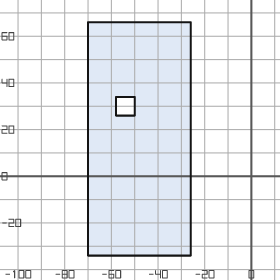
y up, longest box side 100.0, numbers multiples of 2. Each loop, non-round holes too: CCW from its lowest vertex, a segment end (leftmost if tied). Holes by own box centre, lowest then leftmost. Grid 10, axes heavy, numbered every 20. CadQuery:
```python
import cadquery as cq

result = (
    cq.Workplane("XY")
    .moveTo(-70.0, -34.0)
    .lineTo(-26.0, -34.0)
    .lineTo(-26.0, 66.0)
    .lineTo(-70.0, 66.0)
    .close()
    .moveTo(-58.0, 26.0)
    .lineTo(-50.0, 26.0)
    .lineTo(-50.0, 34.0)
    .lineTo(-58.0, 34.0)
    .close()
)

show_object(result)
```